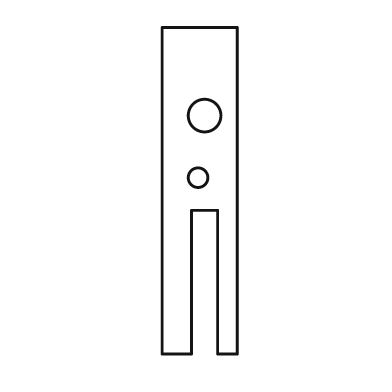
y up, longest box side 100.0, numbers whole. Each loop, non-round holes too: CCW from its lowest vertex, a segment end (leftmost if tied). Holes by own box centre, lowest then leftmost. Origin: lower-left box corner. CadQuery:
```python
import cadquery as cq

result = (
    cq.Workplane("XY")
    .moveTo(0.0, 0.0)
    .lineTo(9.0, 0.0)
    .lineTo(9.0, 44.0)
    .lineTo(17.0, 44.0)
    .lineTo(17.0, 0.0)
    .lineTo(23.0, 0.0)
    .lineTo(23.0, 100.0)
    .lineTo(0.0, 100.0)
    .close()
    .moveTo(11.0, 54.0)
    .circle(3.0)
    .moveTo(13.0, 73.0)
    .circle(5.0)
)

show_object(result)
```